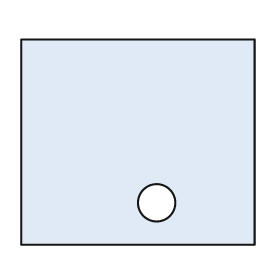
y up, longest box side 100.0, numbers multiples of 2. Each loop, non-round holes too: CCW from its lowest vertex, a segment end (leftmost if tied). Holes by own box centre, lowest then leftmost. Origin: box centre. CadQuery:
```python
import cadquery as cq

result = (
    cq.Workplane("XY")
    .moveTo(-50.0, -44.0)
    .lineTo(50.0, -44.0)
    .lineTo(50.0, 44.0)
    .lineTo(-50.0, 44.0)
    .close()
    .moveTo(8.0, -26.0)
    .circle(8.0)
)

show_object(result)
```